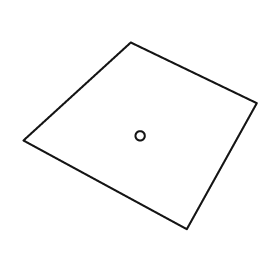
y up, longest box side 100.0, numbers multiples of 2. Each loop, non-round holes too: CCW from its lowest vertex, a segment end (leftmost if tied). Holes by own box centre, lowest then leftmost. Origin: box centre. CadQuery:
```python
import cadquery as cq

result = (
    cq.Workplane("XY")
    .moveTo(20.0, -40.0)
    .lineTo(50.0, 14.0)
    .lineTo(-4.0, 40.0)
    .lineTo(-50.0, -2.0)
    .close()
    .moveTo(0.0, 0.0)
    .circle(2.0)
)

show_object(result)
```